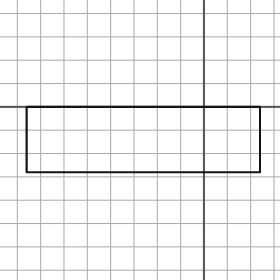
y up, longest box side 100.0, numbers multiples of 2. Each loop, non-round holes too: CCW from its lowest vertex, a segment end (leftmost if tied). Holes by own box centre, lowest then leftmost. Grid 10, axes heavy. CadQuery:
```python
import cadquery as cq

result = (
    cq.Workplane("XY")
    .moveTo(-76.0, -28.0)
    .lineTo(24.0, -28.0)
    .lineTo(24.0, 0.0)
    .lineTo(-76.0, 0.0)
    .close()
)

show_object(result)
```